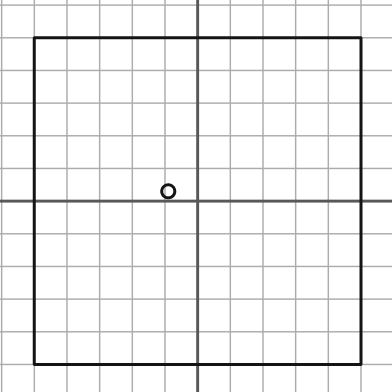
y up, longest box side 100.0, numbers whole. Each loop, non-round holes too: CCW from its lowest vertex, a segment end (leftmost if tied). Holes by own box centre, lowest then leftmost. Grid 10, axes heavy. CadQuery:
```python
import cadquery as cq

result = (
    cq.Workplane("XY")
    .moveTo(-50.0, -50.0)
    .lineTo(50.0, -50.0)
    .lineTo(50.0, 50.0)
    .lineTo(-50.0, 50.0)
    .close()
    .moveTo(-9.0, 3.0)
    .circle(2.0)
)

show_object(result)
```